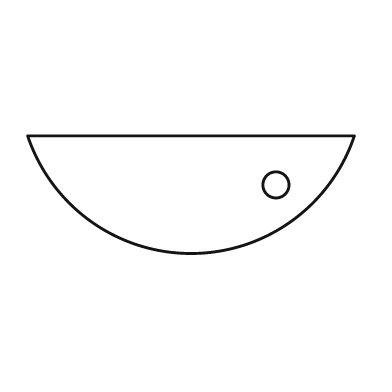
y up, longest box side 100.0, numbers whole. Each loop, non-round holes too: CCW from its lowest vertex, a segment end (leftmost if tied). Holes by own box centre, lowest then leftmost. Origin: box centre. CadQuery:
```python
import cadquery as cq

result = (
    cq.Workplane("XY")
    .moveTo(-50.0, 18.0)
    .threePointArc((0.0, -18.0), (50.0, 18.0))
    .close()
    .moveTo(26.0, 3.0)
    .circle(4.0)
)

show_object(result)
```